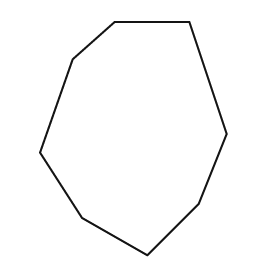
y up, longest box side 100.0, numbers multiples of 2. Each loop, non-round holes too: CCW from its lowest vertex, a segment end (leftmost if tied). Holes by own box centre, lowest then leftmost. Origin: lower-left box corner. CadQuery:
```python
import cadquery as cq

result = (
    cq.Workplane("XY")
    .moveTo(46.0, 0.0)
    .lineTo(68.0, 22.0)
    .lineTo(80.0, 52.0)
    .lineTo(64.0, 100.0)
    .lineTo(32.0, 100.0)
    .lineTo(14.0, 84.0)
    .lineTo(0.0, 44.0)
    .lineTo(18.0, 16.0)
    .close()
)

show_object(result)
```